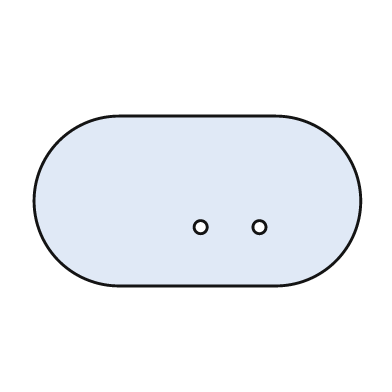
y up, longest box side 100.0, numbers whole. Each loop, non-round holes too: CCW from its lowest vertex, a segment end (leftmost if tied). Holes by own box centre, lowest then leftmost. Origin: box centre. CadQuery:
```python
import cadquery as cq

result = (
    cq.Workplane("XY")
    .moveTo(-24.0, -26.0)
    .lineTo(24.0, -26.0)
    .threePointArc((50.0, 0.0), (24.0, 26.0))
    .lineTo(-24.0, 26.0)
    .threePointArc((-50.0, 0.0), (-24.0, -26.0))
    .close()
    .moveTo(1.0, -8.0)
    .circle(2.0)
    .moveTo(19.0, -8.0)
    .circle(2.0)
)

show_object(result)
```